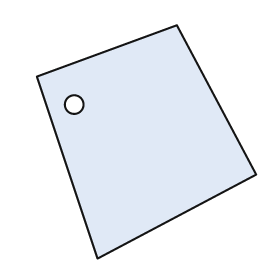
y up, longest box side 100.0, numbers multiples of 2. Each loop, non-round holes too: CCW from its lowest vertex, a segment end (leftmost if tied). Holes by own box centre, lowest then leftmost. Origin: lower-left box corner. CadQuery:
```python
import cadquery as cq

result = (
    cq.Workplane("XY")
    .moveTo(26.0, 0.0)
    .lineTo(94.0, 36.0)
    .lineTo(60.0, 100.0)
    .lineTo(0.0, 78.0)
    .close()
    .moveTo(16.0, 66.0)
    .circle(4.0)
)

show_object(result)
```